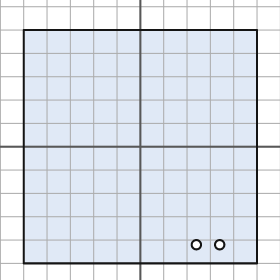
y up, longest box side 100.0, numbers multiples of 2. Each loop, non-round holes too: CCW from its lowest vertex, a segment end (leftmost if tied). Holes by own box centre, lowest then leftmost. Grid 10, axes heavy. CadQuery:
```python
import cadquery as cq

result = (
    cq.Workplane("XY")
    .moveTo(-50.0, -50.0)
    .lineTo(50.0, -50.0)
    .lineTo(50.0, 50.0)
    .lineTo(-50.0, 50.0)
    .close()
    .moveTo(24.0, -42.0)
    .circle(2.0)
    .moveTo(34.0, -42.0)
    .circle(2.0)
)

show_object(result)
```